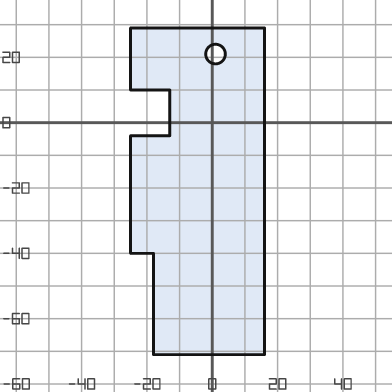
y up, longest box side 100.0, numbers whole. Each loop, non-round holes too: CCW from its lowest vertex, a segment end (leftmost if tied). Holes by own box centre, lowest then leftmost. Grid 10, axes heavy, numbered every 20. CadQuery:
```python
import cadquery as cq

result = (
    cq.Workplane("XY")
    .moveTo(-18.0, -71.0)
    .lineTo(16.0, -71.0)
    .lineTo(16.0, 29.0)
    .lineTo(-25.0, 29.0)
    .lineTo(-25.0, 10.0)
    .lineTo(-13.0, 10.0)
    .lineTo(-13.0, -4.0)
    .lineTo(-25.0, -4.0)
    .lineTo(-25.0, -40.0)
    .lineTo(-18.0, -40.0)
    .close()
    .moveTo(1.0, 21.0)
    .circle(3.0)
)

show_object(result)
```